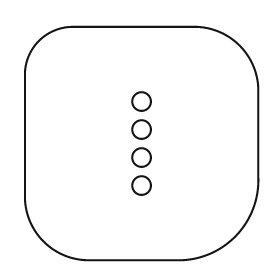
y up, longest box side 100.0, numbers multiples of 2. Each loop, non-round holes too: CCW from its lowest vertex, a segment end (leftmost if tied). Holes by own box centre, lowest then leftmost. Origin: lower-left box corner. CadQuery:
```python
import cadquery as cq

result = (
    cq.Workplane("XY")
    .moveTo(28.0, 0.0)
    .lineTo(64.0, 0.0)
    .threePointArc((90.0, 10.0), (100.0, 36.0))
    .lineTo(100.0, 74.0)
    .threePointArc((92.0, 92.0), (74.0, 100.0))
    .lineTo(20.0, 100.0)
    .threePointArc((6.0, 94.0), (0.0, 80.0))
    .lineTo(0.0, 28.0)
    .threePointArc((8.0, 8.0), (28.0, 0.0))
    .close()
    .moveTo(50.0, 32.0)
    .circle(4.0)
    .moveTo(50.0, 44.0)
    .circle(4.0)
    .moveTo(50.0, 56.0)
    .circle(4.0)
    .moveTo(50.0, 68.0)
    .circle(4.0)
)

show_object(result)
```